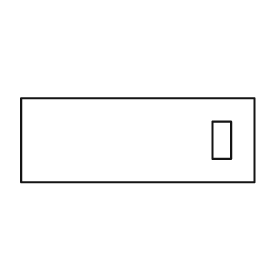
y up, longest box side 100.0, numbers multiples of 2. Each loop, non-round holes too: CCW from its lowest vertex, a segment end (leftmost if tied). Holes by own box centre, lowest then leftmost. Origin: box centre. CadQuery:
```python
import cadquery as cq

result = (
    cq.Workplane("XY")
    .moveTo(-50.0, -18.0)
    .lineTo(50.0, -18.0)
    .lineTo(50.0, 18.0)
    .lineTo(-50.0, 18.0)
    .close()
    .moveTo(32.0, -8.0)
    .lineTo(40.0, -8.0)
    .lineTo(40.0, 8.0)
    .lineTo(32.0, 8.0)
    .close()
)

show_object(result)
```